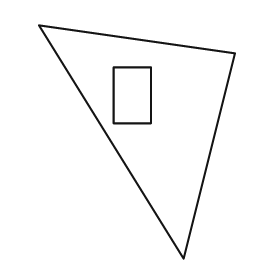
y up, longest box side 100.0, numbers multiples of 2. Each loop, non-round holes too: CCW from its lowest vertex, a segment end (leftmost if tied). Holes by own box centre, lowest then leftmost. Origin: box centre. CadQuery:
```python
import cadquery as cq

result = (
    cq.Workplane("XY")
    .moveTo(20.0, -50.0)
    .lineTo(42.0, 38.0)
    .lineTo(-42.0, 50.0)
    .close()
    .moveTo(-10.0, 8.0)
    .lineTo(6.0, 8.0)
    .lineTo(6.0, 32.0)
    .lineTo(-10.0, 32.0)
    .close()
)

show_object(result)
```